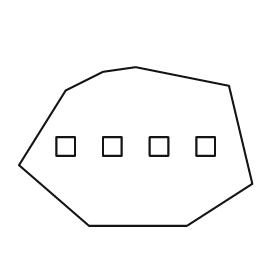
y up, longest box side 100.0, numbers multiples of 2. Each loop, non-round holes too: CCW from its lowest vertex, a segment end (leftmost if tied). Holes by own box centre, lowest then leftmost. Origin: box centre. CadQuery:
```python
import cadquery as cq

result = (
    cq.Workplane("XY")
    .moveTo(-20.0, -34.0)
    .lineTo(22.0, -34.0)
    .lineTo(50.0, -16.0)
    .lineTo(40.0, 26.0)
    .lineTo(0.0, 34.0)
    .lineTo(-14.0, 32.0)
    .lineTo(-30.0, 24.0)
    .lineTo(-50.0, -8.0)
    .close()
    .moveTo(-34.0, -4.0)
    .lineTo(-26.0, -4.0)
    .lineTo(-26.0, 4.0)
    .lineTo(-34.0, 4.0)
    .close()
    .moveTo(-14.0, -4.0)
    .lineTo(-6.0, -4.0)
    .lineTo(-6.0, 4.0)
    .lineTo(-14.0, 4.0)
    .close()
    .moveTo(6.0, -4.0)
    .lineTo(14.0, -4.0)
    .lineTo(14.0, 4.0)
    .lineTo(6.0, 4.0)
    .close()
    .moveTo(26.0, -4.0)
    .lineTo(34.0, -4.0)
    .lineTo(34.0, 4.0)
    .lineTo(26.0, 4.0)
    .close()
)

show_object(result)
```